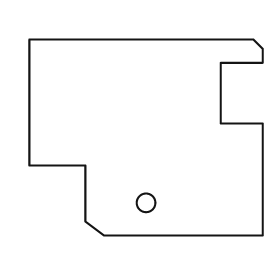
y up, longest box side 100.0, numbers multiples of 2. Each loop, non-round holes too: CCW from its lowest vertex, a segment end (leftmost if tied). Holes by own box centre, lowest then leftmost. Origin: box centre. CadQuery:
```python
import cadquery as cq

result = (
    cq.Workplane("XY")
    .moveTo(-18.0, -42.0)
    .lineTo(50.0, -42.0)
    .lineTo(50.0, 6.0)
    .lineTo(32.0, 6.0)
    .lineTo(32.0, 32.0)
    .lineTo(50.0, 32.0)
    .lineTo(50.0, 38.0)
    .lineTo(46.0, 42.0)
    .lineTo(-50.0, 42.0)
    .lineTo(-50.0, -12.0)
    .lineTo(-26.0, -12.0)
    .lineTo(-26.0, -36.0)
    .close()
    .moveTo(0.0, -28.0)
    .circle(4.0)
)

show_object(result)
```